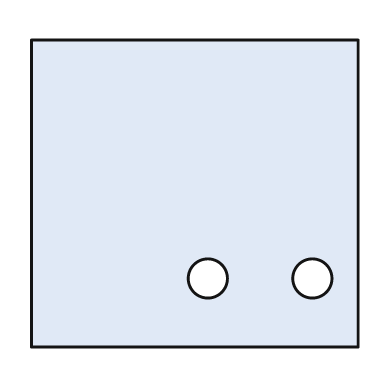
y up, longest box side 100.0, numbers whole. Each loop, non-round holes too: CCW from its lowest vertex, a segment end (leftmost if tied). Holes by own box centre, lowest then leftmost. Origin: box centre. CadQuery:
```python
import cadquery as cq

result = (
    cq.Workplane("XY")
    .moveTo(-50.0, -47.0)
    .lineTo(50.0, -47.0)
    .lineTo(50.0, 47.0)
    .lineTo(-50.0, 47.0)
    .close()
    .moveTo(4.0, -26.0)
    .circle(6.0)
    .moveTo(36.0, -26.0)
    .circle(6.0)
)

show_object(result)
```